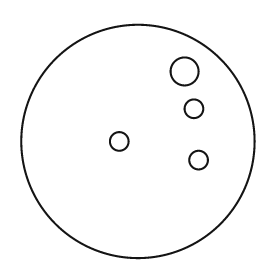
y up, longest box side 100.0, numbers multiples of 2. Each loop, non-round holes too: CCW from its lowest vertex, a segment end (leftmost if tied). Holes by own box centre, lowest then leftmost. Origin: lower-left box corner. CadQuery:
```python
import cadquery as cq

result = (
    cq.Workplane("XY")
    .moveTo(50.0, 50.0)
    .circle(50.0)
    .moveTo(76.0, 42.0)
    .circle(4.0)
    .moveTo(42.0, 50.0)
    .circle(4.0)
    .moveTo(74.0, 64.0)
    .circle(4.0)
    .moveTo(70.0, 80.0)
    .circle(6.0)
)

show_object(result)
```